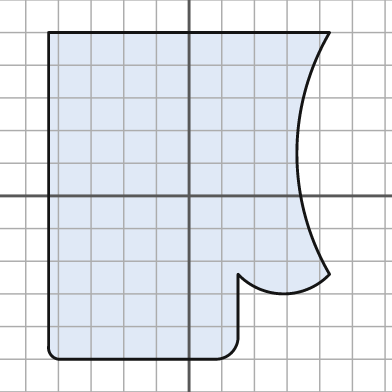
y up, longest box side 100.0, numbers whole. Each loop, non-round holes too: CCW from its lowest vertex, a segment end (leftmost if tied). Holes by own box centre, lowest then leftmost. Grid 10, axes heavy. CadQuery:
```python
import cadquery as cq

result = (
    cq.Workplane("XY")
    .moveTo(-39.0, -50.0)
    .lineTo(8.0, -50.0)
    .threePointArc((13.0, -48.0), (15.0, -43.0))
    .lineTo(15.0, -24.0)
    .threePointArc((29.0, -30.0), (43.0, -24.0))
    .threePointArc((33.0, 13.0), (43.0, 50.0))
    .lineTo(-43.0, 50.0)
    .lineTo(-43.0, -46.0)
    .threePointArc((-42.0, -49.0), (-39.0, -50.0))
    .close()
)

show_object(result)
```